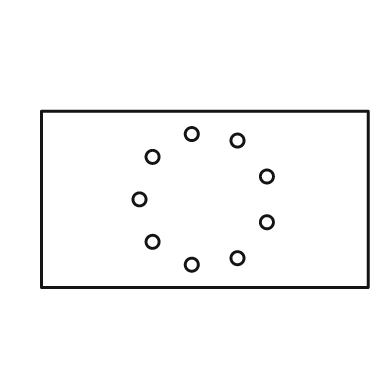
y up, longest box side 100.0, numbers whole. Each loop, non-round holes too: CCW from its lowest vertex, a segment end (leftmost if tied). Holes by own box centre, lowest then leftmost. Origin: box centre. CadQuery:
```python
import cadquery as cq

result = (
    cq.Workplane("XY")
    .moveTo(-50.0, -27.0)
    .lineTo(50.0, -27.0)
    .lineTo(50.0, 27.0)
    .lineTo(-50.0, 27.0)
    .close()
    .moveTo(-4.0, -20.0)
    .circle(2.0)
    .moveTo(10.0, -18.0)
    .circle(2.0)
    .moveTo(-16.0, -13.0)
    .circle(2.0)
    .moveTo(19.0, -7.0)
    .circle(2.0)
    .moveTo(-20.0, 0.0)
    .circle(2.0)
    .moveTo(19.0, 7.0)
    .circle(2.0)
    .moveTo(-16.0, 13.0)
    .circle(2.0)
    .moveTo(10.0, 18.0)
    .circle(2.0)
    .moveTo(-4.0, 20.0)
    .circle(2.0)
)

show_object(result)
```